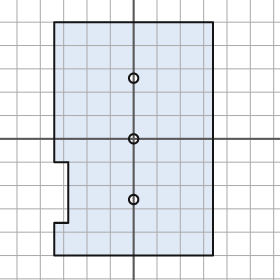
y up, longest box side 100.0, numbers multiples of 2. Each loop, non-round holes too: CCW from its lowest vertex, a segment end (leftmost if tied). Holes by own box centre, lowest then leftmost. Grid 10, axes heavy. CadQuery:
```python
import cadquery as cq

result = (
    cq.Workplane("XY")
    .moveTo(-34.0, -50.0)
    .lineTo(34.0, -50.0)
    .lineTo(34.0, 50.0)
    .lineTo(-34.0, 50.0)
    .lineTo(-34.0, -10.0)
    .lineTo(-28.0, -10.0)
    .lineTo(-28.0, -36.0)
    .lineTo(-34.0, -36.0)
    .close()
    .moveTo(0.0, -26.0)
    .circle(2.0)
    .moveTo(0.0, 0.0)
    .circle(2.0)
    .moveTo(0.0, 26.0)
    .circle(2.0)
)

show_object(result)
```